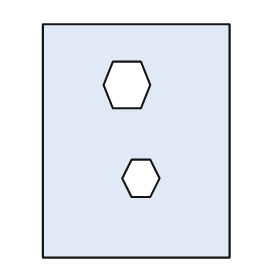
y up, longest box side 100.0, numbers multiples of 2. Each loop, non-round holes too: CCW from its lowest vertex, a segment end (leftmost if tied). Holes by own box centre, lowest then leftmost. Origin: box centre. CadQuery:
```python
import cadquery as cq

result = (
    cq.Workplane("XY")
    .moveTo(-40.0, -50.0)
    .lineTo(40.0, -50.0)
    .lineTo(40.0, 50.0)
    .lineTo(-40.0, 50.0)
    .close()
    .moveTo(-2.0, -24.0)
    .lineTo(6.0, -24.0)
    .lineTo(10.0, -16.0)
    .lineTo(6.0, -8.0)
    .lineTo(-2.0, -8.0)
    .lineTo(-6.0, -16.0)
    .close()
    .moveTo(-10.0, 14.0)
    .lineTo(2.0, 14.0)
    .lineTo(6.0, 24.0)
    .lineTo(2.0, 34.0)
    .lineTo(-10.0, 34.0)
    .lineTo(-14.0, 24.0)
    .close()
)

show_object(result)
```